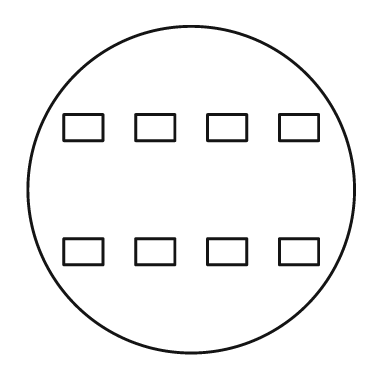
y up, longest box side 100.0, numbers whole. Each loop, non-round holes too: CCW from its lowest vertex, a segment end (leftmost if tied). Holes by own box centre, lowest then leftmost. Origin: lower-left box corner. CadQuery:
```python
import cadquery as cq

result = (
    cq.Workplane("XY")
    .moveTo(50.0, 50.0)
    .circle(50.0)
    .moveTo(11.0, 27.0)
    .lineTo(23.0, 27.0)
    .lineTo(23.0, 35.0)
    .lineTo(11.0, 35.0)
    .close()
    .moveTo(33.0, 27.0)
    .lineTo(45.0, 27.0)
    .lineTo(45.0, 35.0)
    .lineTo(33.0, 35.0)
    .close()
    .moveTo(55.0, 27.0)
    .lineTo(67.0, 27.0)
    .lineTo(67.0, 35.0)
    .lineTo(55.0, 35.0)
    .close()
    .moveTo(77.0, 27.0)
    .lineTo(89.0, 27.0)
    .lineTo(89.0, 35.0)
    .lineTo(77.0, 35.0)
    .close()
    .moveTo(11.0, 65.0)
    .lineTo(23.0, 65.0)
    .lineTo(23.0, 73.0)
    .lineTo(11.0, 73.0)
    .close()
    .moveTo(33.0, 65.0)
    .lineTo(45.0, 65.0)
    .lineTo(45.0, 73.0)
    .lineTo(33.0, 73.0)
    .close()
    .moveTo(55.0, 65.0)
    .lineTo(67.0, 65.0)
    .lineTo(67.0, 73.0)
    .lineTo(55.0, 73.0)
    .close()
    .moveTo(77.0, 65.0)
    .lineTo(89.0, 65.0)
    .lineTo(89.0, 73.0)
    .lineTo(77.0, 73.0)
    .close()
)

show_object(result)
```